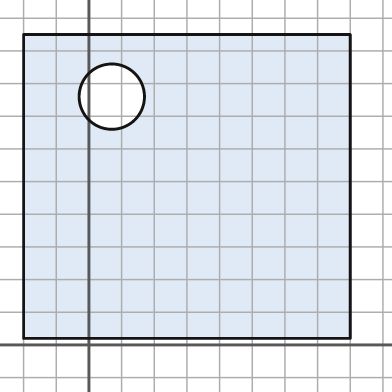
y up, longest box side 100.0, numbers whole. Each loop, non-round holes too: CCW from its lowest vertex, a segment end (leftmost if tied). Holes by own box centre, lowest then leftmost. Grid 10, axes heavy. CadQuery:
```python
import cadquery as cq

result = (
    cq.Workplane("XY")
    .moveTo(-20.0, 2.0)
    .lineTo(80.0, 2.0)
    .lineTo(80.0, 95.0)
    .lineTo(-20.0, 95.0)
    .close()
    .moveTo(7.0, 76.0)
    .circle(10.0)
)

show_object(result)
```